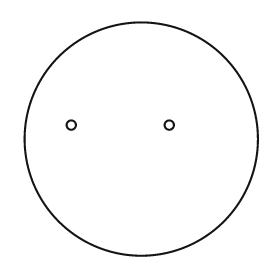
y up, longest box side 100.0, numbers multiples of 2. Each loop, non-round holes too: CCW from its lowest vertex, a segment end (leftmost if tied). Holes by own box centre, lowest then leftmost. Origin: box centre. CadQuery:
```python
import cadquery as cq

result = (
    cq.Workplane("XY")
    .moveTo(0.0, 0.0)
    .circle(50.0)
    .moveTo(-30.0, 6.0)
    .circle(2.0)
    .moveTo(12.0, 6.0)
    .circle(2.0)
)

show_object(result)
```